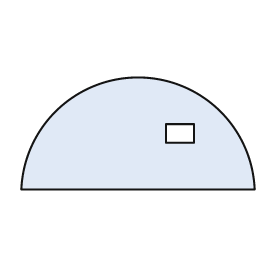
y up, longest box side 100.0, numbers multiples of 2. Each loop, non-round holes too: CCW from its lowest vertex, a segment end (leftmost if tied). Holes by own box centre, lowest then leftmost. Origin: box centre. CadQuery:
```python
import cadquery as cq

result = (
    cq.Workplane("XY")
    .moveTo(-50.0, -24.0)
    .lineTo(50.0, -24.0)
    .threePointArc((0.0, 24.0), (-50.0, -24.0))
    .close()
    .moveTo(12.0, -4.0)
    .lineTo(24.0, -4.0)
    .lineTo(24.0, 4.0)
    .lineTo(12.0, 4.0)
    .close()
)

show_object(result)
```